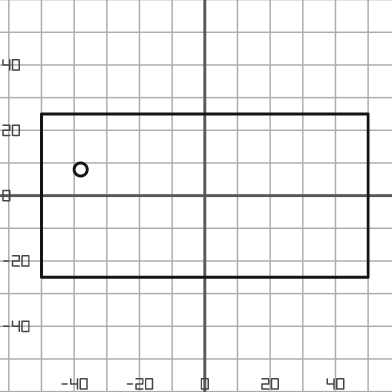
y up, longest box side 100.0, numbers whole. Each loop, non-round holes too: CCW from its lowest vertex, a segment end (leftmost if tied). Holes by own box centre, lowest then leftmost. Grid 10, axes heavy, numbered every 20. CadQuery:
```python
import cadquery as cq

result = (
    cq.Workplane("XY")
    .moveTo(-50.0, -25.0)
    .lineTo(50.0, -25.0)
    .lineTo(50.0, 25.0)
    .lineTo(-50.0, 25.0)
    .close()
    .moveTo(-38.0, 8.0)
    .circle(2.0)
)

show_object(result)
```